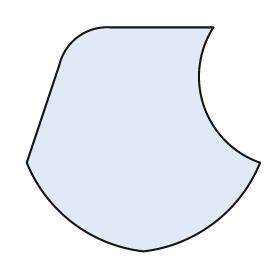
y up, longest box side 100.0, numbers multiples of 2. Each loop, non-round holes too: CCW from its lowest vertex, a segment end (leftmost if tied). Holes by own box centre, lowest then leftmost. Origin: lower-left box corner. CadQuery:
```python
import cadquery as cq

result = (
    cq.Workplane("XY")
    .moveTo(50.0, 0.0)
    .threePointArc((80.0, 12.0), (100.0, 38.0))
    .threePointArc((76.0, 62.0), (80.0, 96.0))
    .lineTo(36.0, 96.0)
    .threePointArc((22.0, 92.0), (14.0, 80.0))
    .lineTo(0.0, 38.0)
    .threePointArc((20.0, 12.0), (50.0, 0.0))
    .close()
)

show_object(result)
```